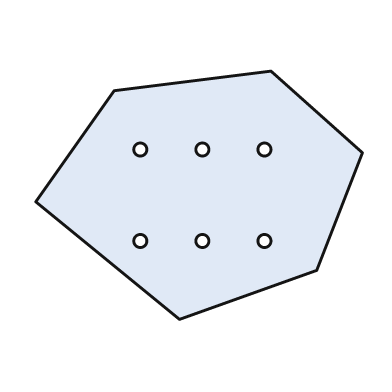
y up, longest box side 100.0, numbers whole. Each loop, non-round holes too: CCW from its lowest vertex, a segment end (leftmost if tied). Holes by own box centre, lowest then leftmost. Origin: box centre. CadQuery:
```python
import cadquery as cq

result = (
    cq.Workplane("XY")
    .moveTo(-6.0, -38.0)
    .lineTo(36.0, -23.0)
    .lineTo(50.0, 13.0)
    .lineTo(22.0, 38.0)
    .lineTo(-26.0, 32.0)
    .lineTo(-50.0, -2.0)
    .close()
    .moveTo(-18.0, -14.0)
    .circle(2.0)
    .moveTo(1.0, -14.0)
    .circle(2.0)
    .moveTo(20.0, -14.0)
    .circle(2.0)
    .moveTo(-18.0, 14.0)
    .circle(2.0)
    .moveTo(1.0, 14.0)
    .circle(2.0)
    .moveTo(20.0, 14.0)
    .circle(2.0)
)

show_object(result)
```